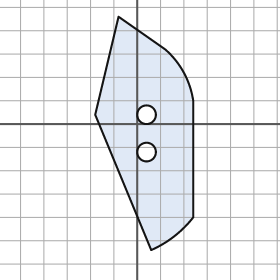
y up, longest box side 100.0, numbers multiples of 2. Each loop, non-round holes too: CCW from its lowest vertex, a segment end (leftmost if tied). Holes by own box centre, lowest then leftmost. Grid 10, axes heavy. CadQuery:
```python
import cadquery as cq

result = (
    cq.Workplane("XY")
    .moveTo(6.0, -54.0)
    .threePointArc((16.0, -48.0), (24.0, -40.0))
    .lineTo(24.0, 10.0)
    .threePointArc((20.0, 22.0), (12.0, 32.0))
    .lineTo(-8.0, 46.0)
    .lineTo(-18.0, 4.0)
    .close()
    .moveTo(4.0, -12.0)
    .circle(4.0)
    .moveTo(4.0, 4.0)
    .circle(4.0)
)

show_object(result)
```